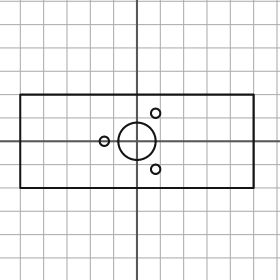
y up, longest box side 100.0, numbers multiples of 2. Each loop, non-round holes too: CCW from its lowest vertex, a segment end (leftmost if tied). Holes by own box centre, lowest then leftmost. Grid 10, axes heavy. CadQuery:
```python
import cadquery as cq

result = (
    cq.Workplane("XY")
    .moveTo(-50.0, -20.0)
    .lineTo(50.0, -20.0)
    .lineTo(50.0, 20.0)
    .lineTo(-50.0, 20.0)
    .close()
    .moveTo(8.0, -12.0)
    .circle(2.0)
    .moveTo(-14.0, 0.0)
    .circle(2.0)
    .moveTo(0.0, 0.0)
    .circle(8.0)
    .moveTo(8.0, 12.0)
    .circle(2.0)
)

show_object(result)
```